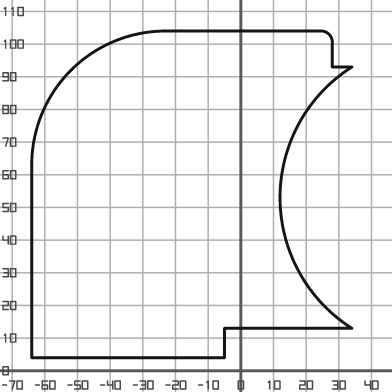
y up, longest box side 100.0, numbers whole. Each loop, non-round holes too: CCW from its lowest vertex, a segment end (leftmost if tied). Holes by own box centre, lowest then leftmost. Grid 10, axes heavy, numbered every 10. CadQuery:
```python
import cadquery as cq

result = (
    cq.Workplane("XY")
    .moveTo(-64.0, 4.0)
    .lineTo(-5.0, 4.0)
    .lineTo(-5.0, 13.0)
    .lineTo(34.0, 13.0)
    .threePointArc((12.0, 53.0), (34.0, 93.0))
    .lineTo(28.0, 93.0)
    .lineTo(28.0, 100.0)
    .threePointArc((27.0, 103.0), (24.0, 104.0))
    .lineTo(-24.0, 104.0)
    .threePointArc((-52.0, 92.0), (-64.0, 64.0))
    .close()
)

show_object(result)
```